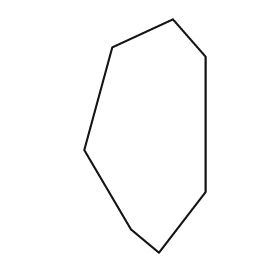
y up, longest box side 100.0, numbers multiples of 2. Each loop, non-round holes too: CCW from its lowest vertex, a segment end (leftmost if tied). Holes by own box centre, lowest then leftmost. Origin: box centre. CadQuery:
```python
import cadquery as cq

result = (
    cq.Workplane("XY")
    .moveTo(6.0, -50.0)
    .lineTo(26.0, -24.0)
    .lineTo(26.0, 34.0)
    .lineTo(12.0, 50.0)
    .lineTo(-14.0, 38.0)
    .lineTo(-26.0, -6.0)
    .lineTo(-6.0, -40.0)
    .close()
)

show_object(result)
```